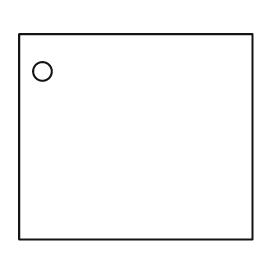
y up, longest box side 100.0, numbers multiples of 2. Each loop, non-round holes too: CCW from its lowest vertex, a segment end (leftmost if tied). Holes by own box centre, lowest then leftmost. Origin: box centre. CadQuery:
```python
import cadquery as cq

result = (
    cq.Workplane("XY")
    .moveTo(-50.0, -44.0)
    .lineTo(50.0, -44.0)
    .lineTo(50.0, 44.0)
    .lineTo(-50.0, 44.0)
    .close()
    .moveTo(-40.0, 28.0)
    .circle(4.0)
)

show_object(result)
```